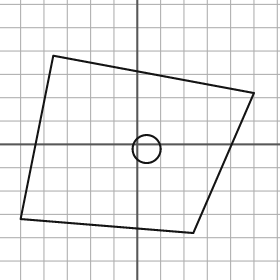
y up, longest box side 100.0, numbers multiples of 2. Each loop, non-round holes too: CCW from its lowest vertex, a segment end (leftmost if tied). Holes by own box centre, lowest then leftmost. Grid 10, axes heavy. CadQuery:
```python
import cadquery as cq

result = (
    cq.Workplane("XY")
    .moveTo(24.0, -38.0)
    .lineTo(50.0, 22.0)
    .lineTo(-36.0, 38.0)
    .lineTo(-50.0, -32.0)
    .close()
    .moveTo(4.0, -2.0)
    .circle(6.0)
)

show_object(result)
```